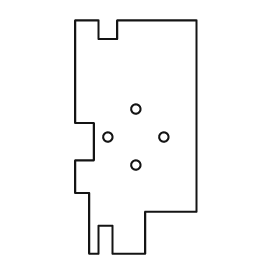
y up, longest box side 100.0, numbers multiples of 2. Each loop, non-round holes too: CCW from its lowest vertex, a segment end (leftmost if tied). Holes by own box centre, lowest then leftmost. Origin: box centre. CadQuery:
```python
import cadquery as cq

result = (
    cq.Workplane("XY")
    .moveTo(-20.0, -50.0)
    .lineTo(-16.0, -50.0)
    .lineTo(-16.0, -38.0)
    .lineTo(-10.0, -38.0)
    .lineTo(-10.0, -50.0)
    .lineTo(4.0, -50.0)
    .lineTo(4.0, -32.0)
    .lineTo(26.0, -32.0)
    .lineTo(26.0, 50.0)
    .lineTo(-8.0, 50.0)
    .lineTo(-8.0, 42.0)
    .lineTo(-16.0, 42.0)
    .lineTo(-16.0, 50.0)
    .lineTo(-26.0, 50.0)
    .lineTo(-26.0, 6.0)
    .lineTo(-18.0, 6.0)
    .lineTo(-18.0, -10.0)
    .lineTo(-26.0, -10.0)
    .lineTo(-26.0, -24.0)
    .lineTo(-20.0, -24.0)
    .close()
    .moveTo(0.0, -12.0)
    .circle(2.0)
    .moveTo(-12.0, 0.0)
    .circle(2.0)
    .moveTo(12.0, 0.0)
    .circle(2.0)
    .moveTo(0.0, 12.0)
    .circle(2.0)
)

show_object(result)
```